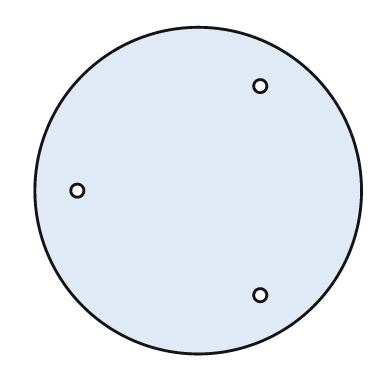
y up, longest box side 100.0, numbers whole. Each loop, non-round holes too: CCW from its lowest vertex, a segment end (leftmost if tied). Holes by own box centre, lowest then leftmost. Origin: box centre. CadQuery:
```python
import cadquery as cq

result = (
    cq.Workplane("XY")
    .moveTo(0.0, 0.0)
    .circle(50.0)
    .moveTo(19.0, -32.0)
    .circle(2.0)
    .moveTo(-37.0, 0.0)
    .circle(2.0)
    .moveTo(19.0, 32.0)
    .circle(2.0)
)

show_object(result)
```